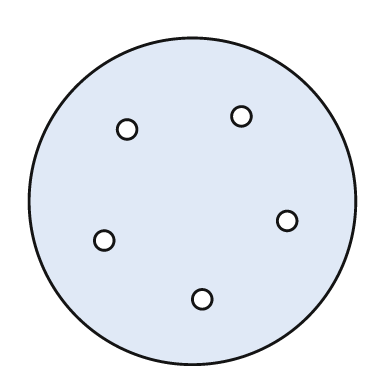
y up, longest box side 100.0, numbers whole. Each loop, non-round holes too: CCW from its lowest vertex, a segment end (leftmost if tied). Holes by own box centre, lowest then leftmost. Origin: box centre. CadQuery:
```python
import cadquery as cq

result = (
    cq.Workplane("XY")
    .moveTo(0.0, 0.0)
    .circle(50.0)
    .moveTo(3.0, -30.0)
    .circle(3.0)
    .moveTo(-27.0, -12.0)
    .circle(3.0)
    .moveTo(29.0, -6.0)
    .circle(3.0)
    .moveTo(-20.0, 22.0)
    .circle(3.0)
    .moveTo(15.0, 26.0)
    .circle(3.0)
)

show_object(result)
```